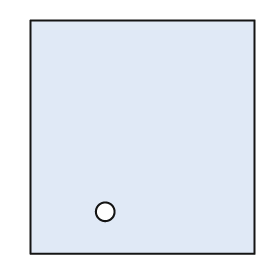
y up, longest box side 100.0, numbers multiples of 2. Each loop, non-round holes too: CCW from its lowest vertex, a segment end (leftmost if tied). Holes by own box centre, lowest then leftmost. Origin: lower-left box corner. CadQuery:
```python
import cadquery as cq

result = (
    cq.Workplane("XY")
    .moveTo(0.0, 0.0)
    .lineTo(96.0, 0.0)
    .lineTo(96.0, 100.0)
    .lineTo(0.0, 100.0)
    .close()
    .moveTo(32.0, 18.0)
    .circle(4.0)
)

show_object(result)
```